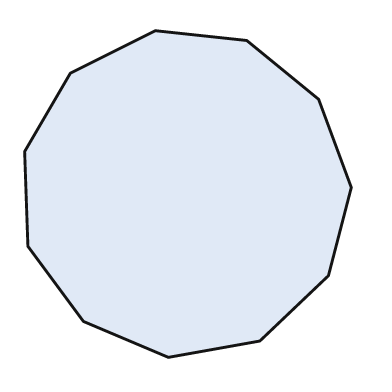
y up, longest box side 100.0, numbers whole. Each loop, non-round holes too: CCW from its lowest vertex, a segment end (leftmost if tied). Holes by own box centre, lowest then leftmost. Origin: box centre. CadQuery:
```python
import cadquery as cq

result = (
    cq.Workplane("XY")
    .moveTo(-6.0, -50.0)
    .lineTo(22.0, -45.0)
    .lineTo(43.0, -25.0)
    .lineTo(50.0, 2.0)
    .lineTo(40.0, 29.0)
    .lineTo(18.0, 47.0)
    .lineTo(-10.0, 50.0)
    .lineTo(-36.0, 37.0)
    .lineTo(-50.0, 13.0)
    .lineTo(-49.0, -16.0)
    .lineTo(-32.0, -39.0)
    .close()
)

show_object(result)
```